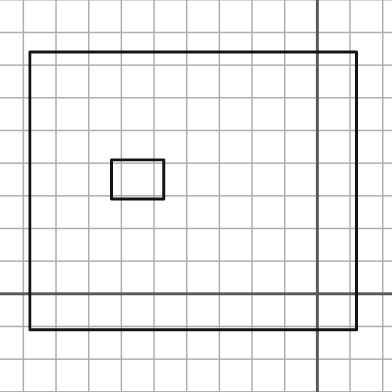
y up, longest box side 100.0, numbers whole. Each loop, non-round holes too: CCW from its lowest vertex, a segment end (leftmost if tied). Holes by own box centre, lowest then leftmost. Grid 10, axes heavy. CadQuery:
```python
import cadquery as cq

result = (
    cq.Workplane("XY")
    .moveTo(-88.0, -11.0)
    .lineTo(12.0, -11.0)
    .lineTo(12.0, 74.0)
    .lineTo(-88.0, 74.0)
    .close()
    .moveTo(-63.0, 29.0)
    .lineTo(-47.0, 29.0)
    .lineTo(-47.0, 41.0)
    .lineTo(-63.0, 41.0)
    .close()
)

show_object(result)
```